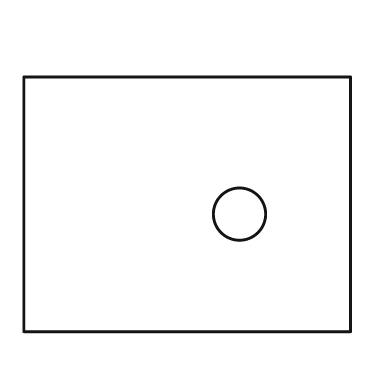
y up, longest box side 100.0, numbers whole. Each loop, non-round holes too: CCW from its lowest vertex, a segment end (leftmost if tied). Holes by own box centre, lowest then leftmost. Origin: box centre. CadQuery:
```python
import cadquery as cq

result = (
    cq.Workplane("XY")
    .moveTo(-50.0, -39.0)
    .lineTo(50.0, -39.0)
    .lineTo(50.0, 39.0)
    .lineTo(-50.0, 39.0)
    .close()
    .moveTo(16.0, -3.0)
    .circle(8.0)
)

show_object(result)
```